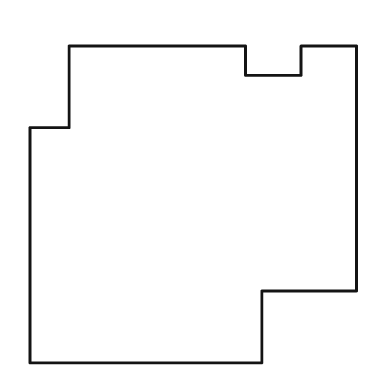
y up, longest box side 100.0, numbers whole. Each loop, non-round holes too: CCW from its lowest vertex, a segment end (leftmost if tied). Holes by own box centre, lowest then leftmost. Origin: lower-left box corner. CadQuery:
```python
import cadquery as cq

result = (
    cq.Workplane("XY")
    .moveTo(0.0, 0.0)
    .lineTo(71.0, 0.0)
    .lineTo(71.0, 22.0)
    .lineTo(100.0, 22.0)
    .lineTo(100.0, 97.0)
    .lineTo(83.0, 97.0)
    .lineTo(83.0, 88.0)
    .lineTo(66.0, 88.0)
    .lineTo(66.0, 97.0)
    .lineTo(12.0, 97.0)
    .lineTo(12.0, 72.0)
    .lineTo(0.0, 72.0)
    .close()
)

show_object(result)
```